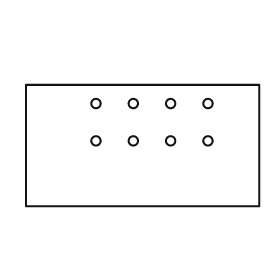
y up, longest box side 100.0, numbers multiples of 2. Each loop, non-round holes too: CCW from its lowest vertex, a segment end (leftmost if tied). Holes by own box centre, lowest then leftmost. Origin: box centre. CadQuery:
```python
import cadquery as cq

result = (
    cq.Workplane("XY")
    .moveTo(-50.0, -26.0)
    .lineTo(50.0, -26.0)
    .lineTo(50.0, 26.0)
    .lineTo(-50.0, 26.0)
    .close()
    .moveTo(-20.0, 2.0)
    .circle(2.0)
    .moveTo(-4.0, 2.0)
    .circle(2.0)
    .moveTo(12.0, 2.0)
    .circle(2.0)
    .moveTo(28.0, 2.0)
    .circle(2.0)
    .moveTo(-20.0, 18.0)
    .circle(2.0)
    .moveTo(-4.0, 18.0)
    .circle(2.0)
    .moveTo(12.0, 18.0)
    .circle(2.0)
    .moveTo(28.0, 18.0)
    .circle(2.0)
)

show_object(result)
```